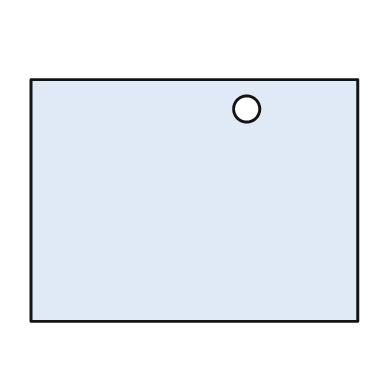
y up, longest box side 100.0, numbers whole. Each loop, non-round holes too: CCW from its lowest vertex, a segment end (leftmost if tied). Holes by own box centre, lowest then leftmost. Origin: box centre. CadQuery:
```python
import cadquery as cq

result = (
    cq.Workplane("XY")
    .moveTo(-50.0, -37.0)
    .lineTo(50.0, -37.0)
    .lineTo(50.0, 37.0)
    .lineTo(-50.0, 37.0)
    .close()
    .moveTo(16.0, 28.0)
    .circle(4.0)
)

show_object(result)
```